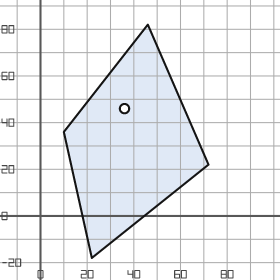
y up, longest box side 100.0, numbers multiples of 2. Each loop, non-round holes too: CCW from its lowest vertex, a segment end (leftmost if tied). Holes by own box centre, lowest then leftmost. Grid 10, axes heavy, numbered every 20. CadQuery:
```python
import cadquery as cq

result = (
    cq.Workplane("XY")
    .moveTo(22.0, -18.0)
    .lineTo(72.0, 22.0)
    .lineTo(46.0, 82.0)
    .lineTo(10.0, 36.0)
    .close()
    .moveTo(36.0, 46.0)
    .circle(2.0)
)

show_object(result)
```